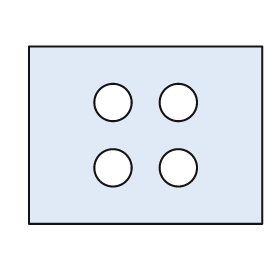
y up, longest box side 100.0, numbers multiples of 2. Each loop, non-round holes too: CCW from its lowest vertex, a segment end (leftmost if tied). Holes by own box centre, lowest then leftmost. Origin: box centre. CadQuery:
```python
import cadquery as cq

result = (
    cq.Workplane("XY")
    .moveTo(-50.0, -38.0)
    .lineTo(50.0, -38.0)
    .lineTo(50.0, 38.0)
    .lineTo(-50.0, 38.0)
    .close()
    .moveTo(-14.0, -14.0)
    .circle(8.0)
    .moveTo(14.0, -14.0)
    .circle(8.0)
    .moveTo(-14.0, 14.0)
    .circle(8.0)
    .moveTo(14.0, 14.0)
    .circle(8.0)
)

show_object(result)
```